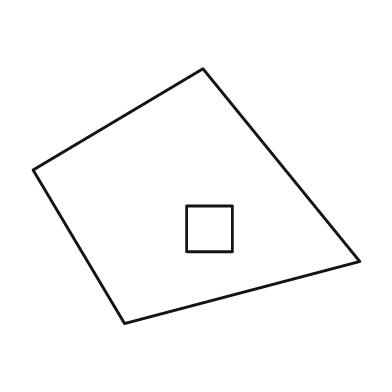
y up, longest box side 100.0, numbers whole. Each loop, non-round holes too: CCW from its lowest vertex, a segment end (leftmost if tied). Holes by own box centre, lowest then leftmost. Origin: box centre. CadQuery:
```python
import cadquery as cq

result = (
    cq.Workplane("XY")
    .moveTo(-22.0, -39.0)
    .lineTo(50.0, -20.0)
    .lineTo(2.0, 39.0)
    .lineTo(-50.0, 8.0)
    .close()
    .moveTo(-3.0, -17.0)
    .lineTo(11.0, -17.0)
    .lineTo(11.0, -3.0)
    .lineTo(-3.0, -3.0)
    .close()
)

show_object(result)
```